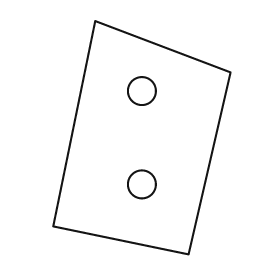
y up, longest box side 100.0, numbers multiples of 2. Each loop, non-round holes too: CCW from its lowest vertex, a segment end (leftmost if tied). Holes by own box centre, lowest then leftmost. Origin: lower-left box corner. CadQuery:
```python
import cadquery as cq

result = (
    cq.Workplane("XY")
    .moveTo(58.0, 0.0)
    .lineTo(76.0, 78.0)
    .lineTo(18.0, 100.0)
    .lineTo(0.0, 12.0)
    .close()
    .moveTo(38.0, 30.0)
    .circle(6.0)
    .moveTo(38.0, 70.0)
    .circle(6.0)
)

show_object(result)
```